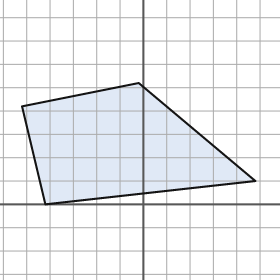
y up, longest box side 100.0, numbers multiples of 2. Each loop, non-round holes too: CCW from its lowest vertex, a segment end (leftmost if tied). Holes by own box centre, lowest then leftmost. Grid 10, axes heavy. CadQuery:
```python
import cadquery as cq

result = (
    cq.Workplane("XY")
    .moveTo(-42.0, 0.0)
    .lineTo(48.0, 10.0)
    .lineTo(-2.0, 52.0)
    .lineTo(-52.0, 42.0)
    .close()
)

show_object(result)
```